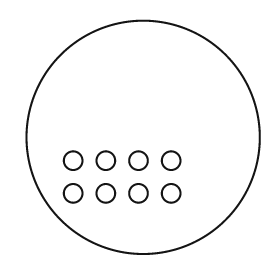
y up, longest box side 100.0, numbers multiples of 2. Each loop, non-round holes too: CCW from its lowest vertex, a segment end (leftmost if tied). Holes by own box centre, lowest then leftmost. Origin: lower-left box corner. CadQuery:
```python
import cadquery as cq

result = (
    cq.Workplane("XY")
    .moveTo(50.0, 50.0)
    .circle(50.0)
    .moveTo(20.0, 26.0)
    .circle(4.0)
    .moveTo(34.0, 26.0)
    .circle(4.0)
    .moveTo(48.0, 26.0)
    .circle(4.0)
    .moveTo(62.0, 26.0)
    .circle(4.0)
    .moveTo(20.0, 40.0)
    .circle(4.0)
    .moveTo(34.0, 40.0)
    .circle(4.0)
    .moveTo(48.0, 40.0)
    .circle(4.0)
    .moveTo(62.0, 40.0)
    .circle(4.0)
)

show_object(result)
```